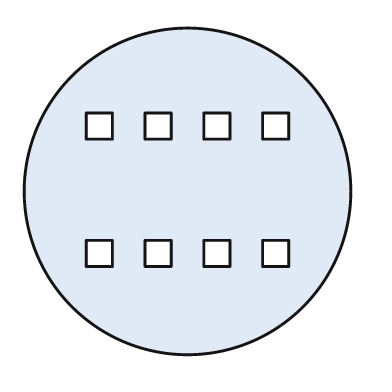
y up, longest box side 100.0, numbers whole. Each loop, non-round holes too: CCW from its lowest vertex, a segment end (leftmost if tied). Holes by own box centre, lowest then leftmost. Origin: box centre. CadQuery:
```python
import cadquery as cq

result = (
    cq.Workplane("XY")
    .moveTo(0.0, 0.0)
    .circle(50.0)
    .moveTo(-31.0, -23.0)
    .lineTo(-23.0, -23.0)
    .lineTo(-23.0, -15.0)
    .lineTo(-31.0, -15.0)
    .close()
    .moveTo(-13.0, -23.0)
    .lineTo(-5.0, -23.0)
    .lineTo(-5.0, -15.0)
    .lineTo(-13.0, -15.0)
    .close()
    .moveTo(5.0, -23.0)
    .lineTo(13.0, -23.0)
    .lineTo(13.0, -15.0)
    .lineTo(5.0, -15.0)
    .close()
    .moveTo(23.0, -23.0)
    .lineTo(31.0, -23.0)
    .lineTo(31.0, -15.0)
    .lineTo(23.0, -15.0)
    .close()
    .moveTo(-31.0, 16.0)
    .lineTo(-23.0, 16.0)
    .lineTo(-23.0, 24.0)
    .lineTo(-31.0, 24.0)
    .close()
    .moveTo(-13.0, 16.0)
    .lineTo(-5.0, 16.0)
    .lineTo(-5.0, 24.0)
    .lineTo(-13.0, 24.0)
    .close()
    .moveTo(5.0, 16.0)
    .lineTo(13.0, 16.0)
    .lineTo(13.0, 24.0)
    .lineTo(5.0, 24.0)
    .close()
    .moveTo(23.0, 16.0)
    .lineTo(31.0, 16.0)
    .lineTo(31.0, 24.0)
    .lineTo(23.0, 24.0)
    .close()
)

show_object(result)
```